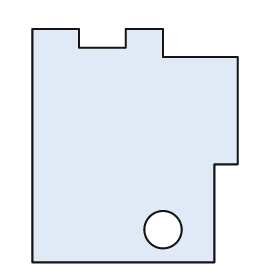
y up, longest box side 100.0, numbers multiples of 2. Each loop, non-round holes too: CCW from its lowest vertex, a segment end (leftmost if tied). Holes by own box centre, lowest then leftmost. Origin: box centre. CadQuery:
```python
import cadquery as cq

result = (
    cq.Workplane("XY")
    .moveTo(-44.0, -50.0)
    .lineTo(34.0, -50.0)
    .lineTo(34.0, -8.0)
    .lineTo(44.0, -8.0)
    .lineTo(44.0, 38.0)
    .lineTo(12.0, 38.0)
    .lineTo(12.0, 50.0)
    .lineTo(-4.0, 50.0)
    .lineTo(-4.0, 42.0)
    .lineTo(-24.0, 42.0)
    .lineTo(-24.0, 50.0)
    .lineTo(-44.0, 50.0)
    .close()
    .moveTo(12.0, -36.0)
    .circle(8.0)
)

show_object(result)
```